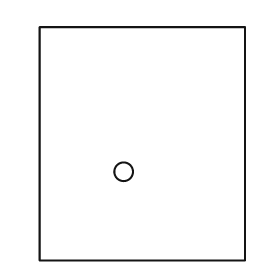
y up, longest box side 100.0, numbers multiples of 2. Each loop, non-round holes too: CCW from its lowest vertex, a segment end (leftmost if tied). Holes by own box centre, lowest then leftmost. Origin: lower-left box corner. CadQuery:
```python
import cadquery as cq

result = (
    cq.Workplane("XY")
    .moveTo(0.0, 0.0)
    .lineTo(88.0, 0.0)
    .lineTo(88.0, 100.0)
    .lineTo(0.0, 100.0)
    .close()
    .moveTo(36.0, 38.0)
    .circle(4.0)
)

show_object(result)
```